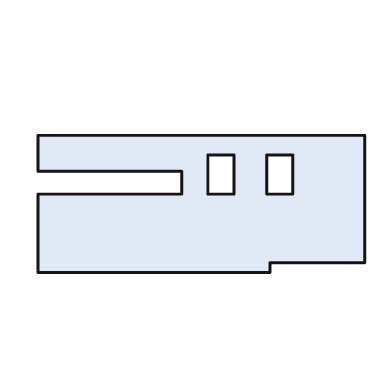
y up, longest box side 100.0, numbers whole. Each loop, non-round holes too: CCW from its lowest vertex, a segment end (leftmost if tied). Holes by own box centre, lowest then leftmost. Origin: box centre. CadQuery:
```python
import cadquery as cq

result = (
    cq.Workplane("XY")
    .moveTo(-50.0, -21.0)
    .lineTo(21.0, -21.0)
    .lineTo(21.0, -18.0)
    .lineTo(50.0, -18.0)
    .lineTo(50.0, 21.0)
    .lineTo(-50.0, 21.0)
    .lineTo(-50.0, 10.0)
    .lineTo(-6.0, 10.0)
    .lineTo(-6.0, 3.0)
    .lineTo(-50.0, 3.0)
    .close()
    .moveTo(2.0, 3.0)
    .lineTo(10.0, 3.0)
    .lineTo(10.0, 15.0)
    .lineTo(2.0, 15.0)
    .close()
    .moveTo(20.0, 3.0)
    .lineTo(28.0, 3.0)
    .lineTo(28.0, 15.0)
    .lineTo(20.0, 15.0)
    .close()
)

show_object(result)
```